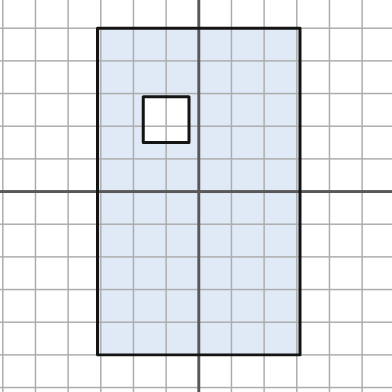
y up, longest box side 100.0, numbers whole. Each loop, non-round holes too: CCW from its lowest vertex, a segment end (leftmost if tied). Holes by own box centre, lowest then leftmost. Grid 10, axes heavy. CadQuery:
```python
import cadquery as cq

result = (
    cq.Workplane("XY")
    .moveTo(-31.0, -50.0)
    .lineTo(31.0, -50.0)
    .lineTo(31.0, 50.0)
    .lineTo(-31.0, 50.0)
    .close()
    .moveTo(-17.0, 15.0)
    .lineTo(-3.0, 15.0)
    .lineTo(-3.0, 29.0)
    .lineTo(-17.0, 29.0)
    .close()
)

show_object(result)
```